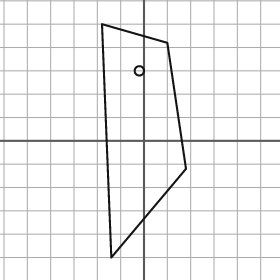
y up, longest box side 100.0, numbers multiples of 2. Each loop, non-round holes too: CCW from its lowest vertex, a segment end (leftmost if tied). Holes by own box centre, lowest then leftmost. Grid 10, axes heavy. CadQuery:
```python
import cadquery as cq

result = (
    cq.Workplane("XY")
    .moveTo(-14.0, -50.0)
    .lineTo(18.0, -12.0)
    .lineTo(10.0, 42.0)
    .lineTo(-18.0, 50.0)
    .close()
    .moveTo(-2.0, 30.0)
    .circle(2.0)
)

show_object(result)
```